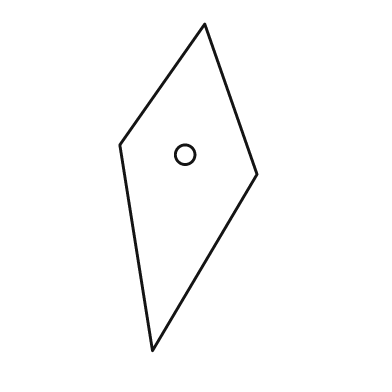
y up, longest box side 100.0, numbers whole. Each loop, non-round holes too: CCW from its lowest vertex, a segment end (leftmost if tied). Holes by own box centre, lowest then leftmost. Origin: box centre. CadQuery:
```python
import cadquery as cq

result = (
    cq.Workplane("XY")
    .moveTo(-11.0, -50.0)
    .lineTo(21.0, 4.0)
    .lineTo(5.0, 50.0)
    .lineTo(-21.0, 13.0)
    .close()
    .moveTo(-1.0, 10.0)
    .circle(3.0)
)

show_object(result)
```